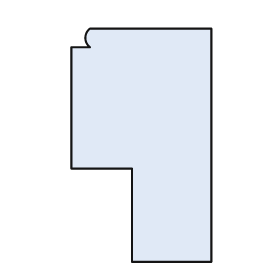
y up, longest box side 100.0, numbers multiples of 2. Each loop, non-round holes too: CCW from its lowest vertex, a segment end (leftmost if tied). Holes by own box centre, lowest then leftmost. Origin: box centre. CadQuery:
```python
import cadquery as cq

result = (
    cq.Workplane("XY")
    .moveTo(-4.0, -50.0)
    .lineTo(30.0, -50.0)
    .lineTo(30.0, 50.0)
    .lineTo(-22.0, 50.0)
    .threePointArc((-24.0, 46.0), (-22.0, 42.0))
    .lineTo(-30.0, 42.0)
    .lineTo(-30.0, -10.0)
    .lineTo(-4.0, -10.0)
    .close()
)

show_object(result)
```